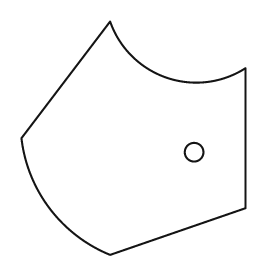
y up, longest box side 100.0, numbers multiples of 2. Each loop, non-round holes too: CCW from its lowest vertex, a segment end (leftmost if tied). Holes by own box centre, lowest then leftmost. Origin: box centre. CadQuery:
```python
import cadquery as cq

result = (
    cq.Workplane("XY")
    .moveTo(-10.0, -50.0)
    .lineTo(48.0, -30.0)
    .lineTo(48.0, 30.0)
    .threePointArc((14.0, 26.0), (-10.0, 50.0))
    .lineTo(-48.0, 0.0)
    .threePointArc((-36.0, -30.0), (-10.0, -50.0))
    .close()
    .moveTo(26.0, -6.0)
    .circle(4.0)
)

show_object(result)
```